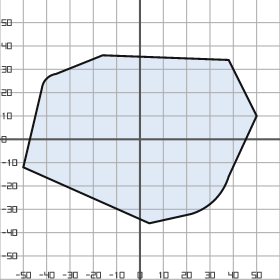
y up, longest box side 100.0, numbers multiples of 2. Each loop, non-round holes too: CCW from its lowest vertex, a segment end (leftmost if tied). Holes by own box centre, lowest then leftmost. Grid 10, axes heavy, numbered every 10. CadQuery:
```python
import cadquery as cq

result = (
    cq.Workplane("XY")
    .moveTo(4.0, -36.0)
    .lineTo(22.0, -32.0)
    .threePointArc((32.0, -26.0), (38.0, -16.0))
    .lineTo(50.0, 10.0)
    .lineTo(38.0, 34.0)
    .lineTo(-16.0, 36.0)
    .lineTo(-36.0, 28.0)
    .threePointArc((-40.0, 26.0), (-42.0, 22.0))
    .lineTo(-50.0, -12.0)
    .close()
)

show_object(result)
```